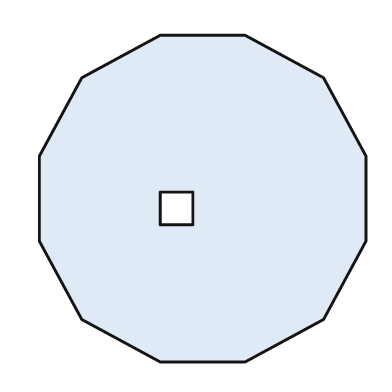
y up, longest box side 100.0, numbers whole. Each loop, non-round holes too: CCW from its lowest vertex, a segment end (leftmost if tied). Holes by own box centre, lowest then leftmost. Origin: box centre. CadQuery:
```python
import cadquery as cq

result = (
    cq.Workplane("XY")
    .moveTo(-13.0, -50.0)
    .lineTo(13.0, -50.0)
    .lineTo(37.0, -37.0)
    .lineTo(50.0, -13.0)
    .lineTo(50.0, 13.0)
    .lineTo(37.0, 37.0)
    .lineTo(13.0, 50.0)
    .lineTo(-13.0, 50.0)
    .lineTo(-37.0, 37.0)
    .lineTo(-50.0, 13.0)
    .lineTo(-50.0, -13.0)
    .lineTo(-37.0, -37.0)
    .close()
    .moveTo(-13.0, -8.0)
    .lineTo(-3.0, -8.0)
    .lineTo(-3.0, 2.0)
    .lineTo(-13.0, 2.0)
    .close()
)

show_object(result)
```